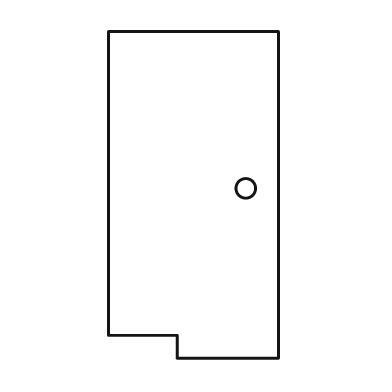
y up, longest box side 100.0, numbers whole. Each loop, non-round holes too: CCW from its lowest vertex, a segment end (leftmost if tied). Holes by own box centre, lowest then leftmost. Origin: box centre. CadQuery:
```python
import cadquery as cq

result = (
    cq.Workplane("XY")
    .moveTo(-5.0, -50.0)
    .lineTo(26.0, -50.0)
    .lineTo(26.0, 50.0)
    .lineTo(-26.0, 50.0)
    .lineTo(-26.0, -43.0)
    .lineTo(-5.0, -43.0)
    .close()
    .moveTo(16.0, 2.0)
    .circle(3.0)
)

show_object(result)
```